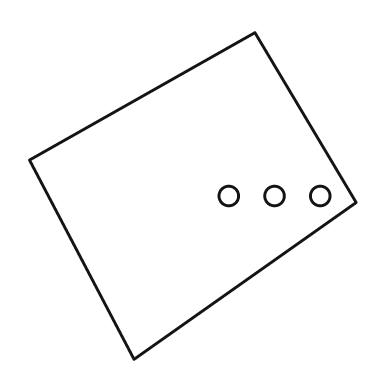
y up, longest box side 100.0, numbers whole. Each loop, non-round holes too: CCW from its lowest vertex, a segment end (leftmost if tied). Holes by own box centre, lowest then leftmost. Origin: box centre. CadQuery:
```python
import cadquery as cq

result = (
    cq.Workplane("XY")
    .moveTo(-18.0, -50.0)
    .lineTo(50.0, -2.0)
    .lineTo(19.0, 50.0)
    .lineTo(-50.0, 11.0)
    .close()
    .moveTo(11.0, 0.0)
    .circle(3.0)
    .moveTo(25.0, 0.0)
    .circle(3.0)
    .moveTo(39.0, 0.0)
    .circle(3.0)
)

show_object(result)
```